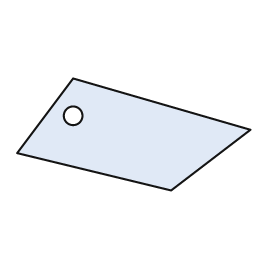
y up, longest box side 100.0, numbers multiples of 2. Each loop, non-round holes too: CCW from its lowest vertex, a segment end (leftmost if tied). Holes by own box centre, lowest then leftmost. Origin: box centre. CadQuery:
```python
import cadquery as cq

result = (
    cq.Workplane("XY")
    .moveTo(16.0, -24.0)
    .lineTo(50.0, 2.0)
    .lineTo(-26.0, 24.0)
    .lineTo(-50.0, -8.0)
    .close()
    .moveTo(-26.0, 8.0)
    .circle(4.0)
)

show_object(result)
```